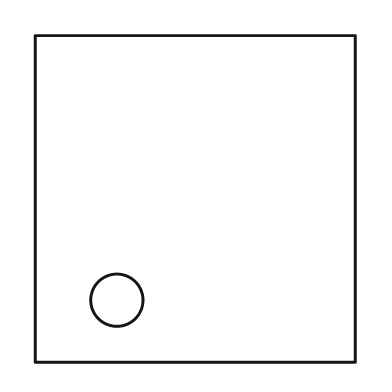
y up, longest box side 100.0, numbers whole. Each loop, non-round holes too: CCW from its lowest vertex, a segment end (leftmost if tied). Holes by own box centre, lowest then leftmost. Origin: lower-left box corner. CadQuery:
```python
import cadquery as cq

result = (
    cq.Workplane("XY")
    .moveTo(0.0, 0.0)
    .lineTo(98.0, 0.0)
    .lineTo(98.0, 100.0)
    .lineTo(0.0, 100.0)
    .close()
    .moveTo(25.0, 19.0)
    .circle(8.0)
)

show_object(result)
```